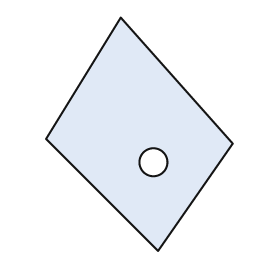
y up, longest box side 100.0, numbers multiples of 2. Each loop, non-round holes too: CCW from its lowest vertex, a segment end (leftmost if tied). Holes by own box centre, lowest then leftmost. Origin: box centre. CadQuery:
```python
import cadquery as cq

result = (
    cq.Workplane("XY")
    .moveTo(8.0, -50.0)
    .lineTo(40.0, -4.0)
    .lineTo(-8.0, 50.0)
    .lineTo(-40.0, -2.0)
    .close()
    .moveTo(6.0, -12.0)
    .circle(6.0)
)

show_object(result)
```